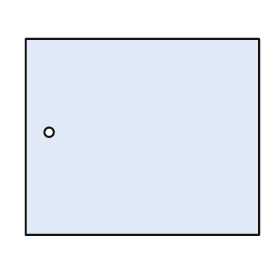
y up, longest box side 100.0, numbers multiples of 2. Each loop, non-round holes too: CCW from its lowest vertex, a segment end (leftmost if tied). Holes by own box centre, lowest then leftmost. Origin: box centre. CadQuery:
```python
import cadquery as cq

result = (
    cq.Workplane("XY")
    .moveTo(-50.0, -42.0)
    .lineTo(50.0, -42.0)
    .lineTo(50.0, 42.0)
    .lineTo(-50.0, 42.0)
    .close()
    .moveTo(-40.0, 2.0)
    .circle(2.0)
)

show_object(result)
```